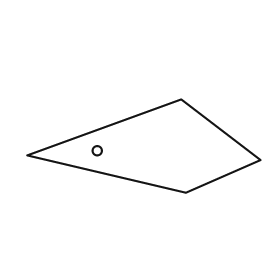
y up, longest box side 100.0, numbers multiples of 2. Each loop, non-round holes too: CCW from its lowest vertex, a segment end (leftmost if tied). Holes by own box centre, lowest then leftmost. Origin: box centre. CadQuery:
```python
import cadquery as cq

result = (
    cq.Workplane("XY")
    .moveTo(18.0, -20.0)
    .lineTo(50.0, -6.0)
    .lineTo(16.0, 20.0)
    .lineTo(-50.0, -4.0)
    .close()
    .moveTo(-20.0, -2.0)
    .circle(2.0)
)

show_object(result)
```